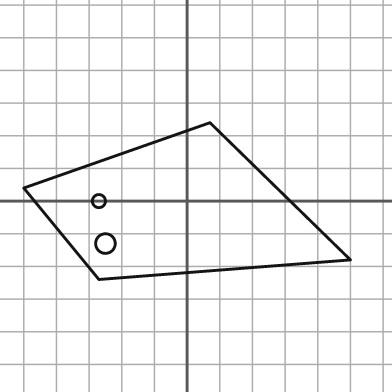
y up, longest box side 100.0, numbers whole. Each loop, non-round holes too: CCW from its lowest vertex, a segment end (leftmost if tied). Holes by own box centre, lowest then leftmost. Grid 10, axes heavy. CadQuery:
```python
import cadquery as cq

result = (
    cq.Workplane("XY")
    .moveTo(-27.0, -24.0)
    .lineTo(50.0, -18.0)
    .lineTo(7.0, 24.0)
    .lineTo(-50.0, 4.0)
    .close()
    .moveTo(-25.0, -13.0)
    .circle(3.0)
    .moveTo(-27.0, 0.0)
    .circle(2.0)
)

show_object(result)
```